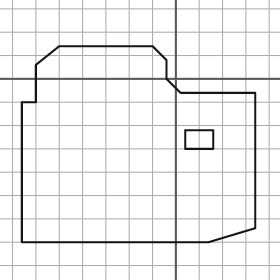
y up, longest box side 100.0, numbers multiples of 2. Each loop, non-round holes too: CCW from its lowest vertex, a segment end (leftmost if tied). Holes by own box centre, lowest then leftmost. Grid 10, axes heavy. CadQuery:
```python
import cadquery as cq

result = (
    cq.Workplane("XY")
    .moveTo(-66.0, -70.0)
    .lineTo(14.0, -70.0)
    .lineTo(34.0, -64.0)
    .lineTo(34.0, -6.0)
    .lineTo(2.0, -6.0)
    .lineTo(-4.0, 0.0)
    .lineTo(-4.0, 8.0)
    .lineTo(-10.0, 14.0)
    .lineTo(-50.0, 14.0)
    .lineTo(-60.0, 6.0)
    .lineTo(-60.0, -10.0)
    .lineTo(-66.0, -10.0)
    .close()
    .moveTo(4.0, -30.0)
    .lineTo(16.0, -30.0)
    .lineTo(16.0, -22.0)
    .lineTo(4.0, -22.0)
    .close()
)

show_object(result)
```